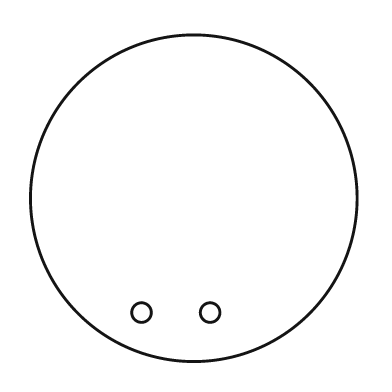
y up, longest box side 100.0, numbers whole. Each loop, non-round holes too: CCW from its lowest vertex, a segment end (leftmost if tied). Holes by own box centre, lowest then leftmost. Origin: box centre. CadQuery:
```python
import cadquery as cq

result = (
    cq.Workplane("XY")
    .moveTo(0.0, 0.0)
    .circle(50.0)
    .moveTo(-16.0, -35.0)
    .circle(3.0)
    .moveTo(5.0, -35.0)
    .circle(3.0)
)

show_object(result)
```